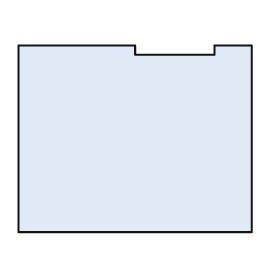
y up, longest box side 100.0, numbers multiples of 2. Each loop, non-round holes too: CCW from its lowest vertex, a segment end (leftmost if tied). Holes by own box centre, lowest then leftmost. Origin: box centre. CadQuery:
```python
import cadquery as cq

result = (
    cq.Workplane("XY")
    .moveTo(-50.0, -40.0)
    .lineTo(50.0, -40.0)
    .lineTo(50.0, 40.0)
    .lineTo(34.0, 40.0)
    .lineTo(34.0, 36.0)
    .lineTo(0.0, 36.0)
    .lineTo(0.0, 40.0)
    .lineTo(-50.0, 40.0)
    .close()
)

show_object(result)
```